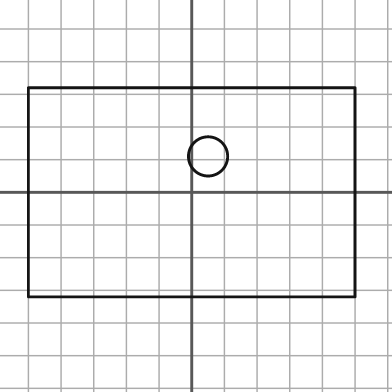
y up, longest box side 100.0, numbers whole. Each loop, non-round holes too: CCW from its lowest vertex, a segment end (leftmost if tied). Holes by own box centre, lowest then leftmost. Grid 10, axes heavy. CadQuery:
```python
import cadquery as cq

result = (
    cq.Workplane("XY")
    .moveTo(-50.0, -32.0)
    .lineTo(50.0, -32.0)
    .lineTo(50.0, 32.0)
    .lineTo(-50.0, 32.0)
    .close()
    .moveTo(5.0, 11.0)
    .circle(6.0)
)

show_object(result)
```